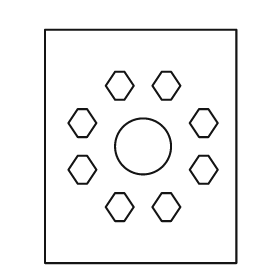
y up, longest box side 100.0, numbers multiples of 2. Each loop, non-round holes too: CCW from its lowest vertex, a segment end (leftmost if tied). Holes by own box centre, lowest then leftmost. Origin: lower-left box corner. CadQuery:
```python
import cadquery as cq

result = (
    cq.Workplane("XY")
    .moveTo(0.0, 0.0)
    .lineTo(82.0, 0.0)
    .lineTo(82.0, 100.0)
    .lineTo(0.0, 100.0)
    .close()
    .moveTo(30.0, 18.0)
    .lineTo(34.0, 18.0)
    .lineTo(38.0, 24.0)
    .lineTo(34.0, 30.0)
    .lineTo(30.0, 30.0)
    .lineTo(26.0, 24.0)
    .close()
    .moveTo(50.0, 18.0)
    .lineTo(54.0, 18.0)
    .lineTo(58.0, 24.0)
    .lineTo(54.0, 30.0)
    .lineTo(50.0, 30.0)
    .lineTo(46.0, 24.0)
    .close()
    .moveTo(14.0, 34.0)
    .lineTo(18.0, 34.0)
    .lineTo(22.0, 40.0)
    .lineTo(18.0, 46.0)
    .lineTo(14.0, 46.0)
    .lineTo(10.0, 40.0)
    .close()
    .moveTo(66.0, 34.0)
    .lineTo(70.0, 34.0)
    .lineTo(74.0, 40.0)
    .lineTo(70.0, 46.0)
    .lineTo(66.0, 46.0)
    .lineTo(62.0, 40.0)
    .close()
    .moveTo(42.0, 50.0)
    .circle(12.0)
    .moveTo(14.0, 54.0)
    .lineTo(18.0, 54.0)
    .lineTo(22.0, 60.0)
    .lineTo(18.0, 66.0)
    .lineTo(14.0, 66.0)
    .lineTo(10.0, 60.0)
    .close()
    .moveTo(66.0, 54.0)
    .lineTo(70.0, 54.0)
    .lineTo(74.0, 60.0)
    .lineTo(70.0, 66.0)
    .lineTo(66.0, 66.0)
    .lineTo(62.0, 60.0)
    .close()
    .moveTo(30.0, 70.0)
    .lineTo(34.0, 70.0)
    .lineTo(38.0, 76.0)
    .lineTo(34.0, 82.0)
    .lineTo(30.0, 82.0)
    .lineTo(26.0, 76.0)
    .close()
    .moveTo(50.0, 70.0)
    .lineTo(54.0, 70.0)
    .lineTo(58.0, 76.0)
    .lineTo(54.0, 82.0)
    .lineTo(50.0, 82.0)
    .lineTo(46.0, 76.0)
    .close()
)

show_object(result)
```